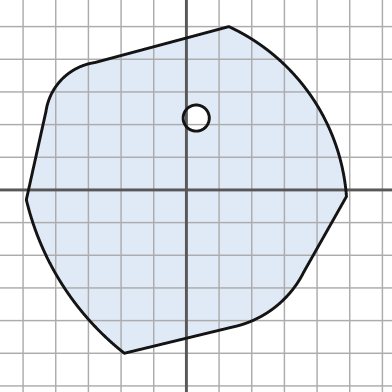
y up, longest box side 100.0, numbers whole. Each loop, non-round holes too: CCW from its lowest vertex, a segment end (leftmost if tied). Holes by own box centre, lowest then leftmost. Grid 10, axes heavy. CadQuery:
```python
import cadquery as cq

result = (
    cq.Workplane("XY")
    .moveTo(-19.0, -50.0)
    .lineTo(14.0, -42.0)
    .threePointArc((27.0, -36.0), (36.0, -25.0))
    .lineTo(49.0, -2.0)
    .threePointArc((38.0, 29.0), (13.0, 50.0))
    .lineTo(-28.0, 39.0)
    .threePointArc((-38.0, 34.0), (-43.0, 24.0))
    .lineTo(-49.0, -3.0)
    .threePointArc((-38.0, -29.0), (-19.0, -50.0))
    .close()
    .moveTo(3.0, 22.0)
    .circle(4.0)
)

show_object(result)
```